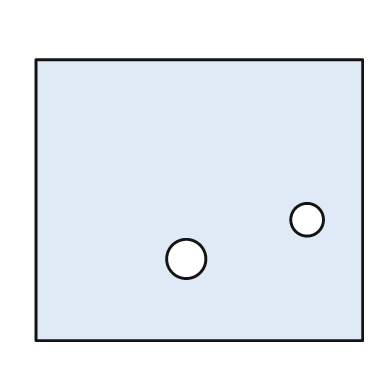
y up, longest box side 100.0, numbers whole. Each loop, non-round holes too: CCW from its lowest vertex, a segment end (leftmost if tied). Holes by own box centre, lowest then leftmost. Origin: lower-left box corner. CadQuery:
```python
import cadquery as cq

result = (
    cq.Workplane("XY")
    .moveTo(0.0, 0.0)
    .lineTo(100.0, 0.0)
    .lineTo(100.0, 86.0)
    .lineTo(0.0, 86.0)
    .close()
    .moveTo(46.0, 25.0)
    .circle(6.0)
    .moveTo(83.0, 37.0)
    .circle(5.0)
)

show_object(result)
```